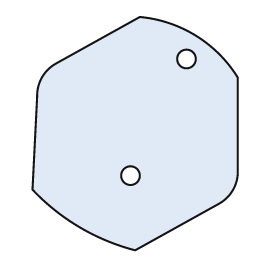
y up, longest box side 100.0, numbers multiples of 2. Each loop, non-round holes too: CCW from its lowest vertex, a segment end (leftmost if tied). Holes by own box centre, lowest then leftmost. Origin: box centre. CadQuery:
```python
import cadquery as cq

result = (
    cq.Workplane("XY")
    .moveTo(0.0, -50.0)
    .lineTo(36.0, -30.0)
    .threePointArc((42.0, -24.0), (44.0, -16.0))
    .lineTo(44.0, 24.0)
    .threePointArc((26.0, 42.0), (2.0, 50.0))
    .lineTo(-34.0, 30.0)
    .threePointArc((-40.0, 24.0), (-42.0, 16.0))
    .lineTo(-44.0, -24.0)
    .threePointArc((-24.0, -40.0), (0.0, -50.0))
    .close()
    .moveTo(-2.0, -18.0)
    .circle(4.0)
    .moveTo(22.0, 32.0)
    .circle(4.0)
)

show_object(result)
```